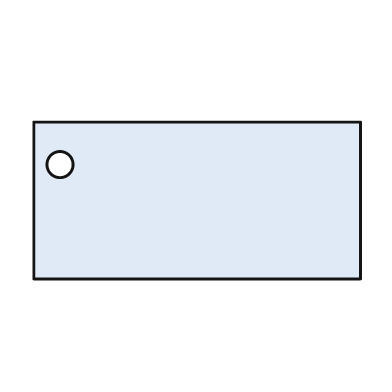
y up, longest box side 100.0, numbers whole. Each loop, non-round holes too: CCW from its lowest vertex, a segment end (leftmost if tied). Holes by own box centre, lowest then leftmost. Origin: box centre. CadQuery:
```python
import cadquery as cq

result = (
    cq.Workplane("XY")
    .moveTo(-50.0, -24.0)
    .lineTo(50.0, -24.0)
    .lineTo(50.0, 24.0)
    .lineTo(-50.0, 24.0)
    .close()
    .moveTo(-42.0, 11.0)
    .circle(4.0)
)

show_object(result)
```